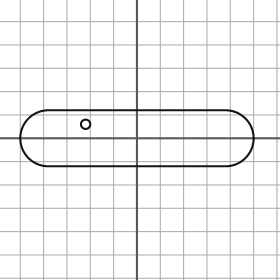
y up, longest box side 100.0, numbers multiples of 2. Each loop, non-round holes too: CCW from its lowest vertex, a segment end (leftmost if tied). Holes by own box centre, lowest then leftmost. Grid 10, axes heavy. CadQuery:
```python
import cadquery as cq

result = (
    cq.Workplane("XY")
    .moveTo(-38.0, -12.0)
    .lineTo(38.0, -12.0)
    .threePointArc((50.0, 0.0), (38.0, 12.0))
    .lineTo(-38.0, 12.0)
    .threePointArc((-50.0, 0.0), (-38.0, -12.0))
    .close()
    .moveTo(-22.0, 6.0)
    .circle(2.0)
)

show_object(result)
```